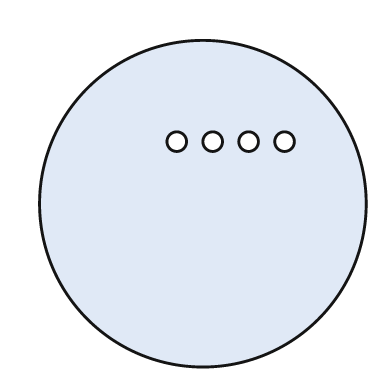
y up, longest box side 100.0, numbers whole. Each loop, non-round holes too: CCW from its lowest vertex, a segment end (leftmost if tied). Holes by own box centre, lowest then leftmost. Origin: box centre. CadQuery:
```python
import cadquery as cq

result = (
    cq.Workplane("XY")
    .moveTo(0.0, 0.0)
    .circle(50.0)
    .moveTo(-8.0, 19.0)
    .circle(3.0)
    .moveTo(3.0, 19.0)
    .circle(3.0)
    .moveTo(14.0, 19.0)
    .circle(3.0)
    .moveTo(25.0, 19.0)
    .circle(3.0)
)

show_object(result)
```